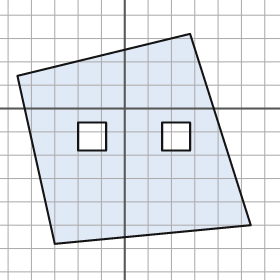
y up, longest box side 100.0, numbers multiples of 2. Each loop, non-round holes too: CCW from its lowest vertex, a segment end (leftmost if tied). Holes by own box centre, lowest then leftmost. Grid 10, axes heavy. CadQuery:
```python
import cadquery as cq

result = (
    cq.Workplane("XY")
    .moveTo(-30.0, -58.0)
    .lineTo(54.0, -50.0)
    .lineTo(28.0, 32.0)
    .lineTo(-46.0, 14.0)
    .close()
    .moveTo(-20.0, -18.0)
    .lineTo(-8.0, -18.0)
    .lineTo(-8.0, -6.0)
    .lineTo(-20.0, -6.0)
    .close()
    .moveTo(16.0, -18.0)
    .lineTo(28.0, -18.0)
    .lineTo(28.0, -6.0)
    .lineTo(16.0, -6.0)
    .close()
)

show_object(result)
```